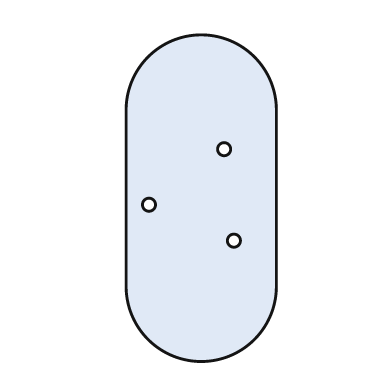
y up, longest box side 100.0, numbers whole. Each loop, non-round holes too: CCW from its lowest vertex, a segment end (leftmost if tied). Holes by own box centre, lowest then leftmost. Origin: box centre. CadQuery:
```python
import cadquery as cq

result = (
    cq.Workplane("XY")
    .moveTo(-23.0, -27.0)
    .threePointArc((0.0, -50.0), (23.0, -27.0))
    .lineTo(23.0, 27.0)
    .threePointArc((0.0, 50.0), (-23.0, 27.0))
    .close()
    .moveTo(10.0, -13.0)
    .circle(2.0)
    .moveTo(-16.0, -2.0)
    .circle(2.0)
    .moveTo(7.0, 15.0)
    .circle(2.0)
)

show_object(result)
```